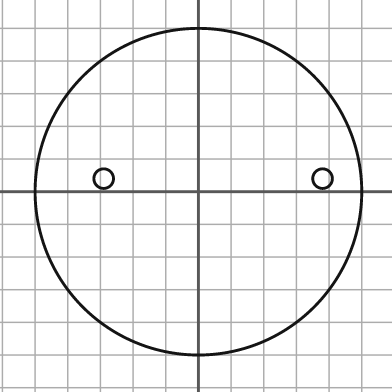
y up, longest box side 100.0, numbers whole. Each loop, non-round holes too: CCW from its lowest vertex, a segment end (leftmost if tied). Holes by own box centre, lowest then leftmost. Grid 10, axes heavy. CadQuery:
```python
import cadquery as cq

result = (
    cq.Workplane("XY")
    .moveTo(0.0, 0.0)
    .circle(50.0)
    .moveTo(-29.0, 4.0)
    .circle(3.0)
    .moveTo(38.0, 4.0)
    .circle(3.0)
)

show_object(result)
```